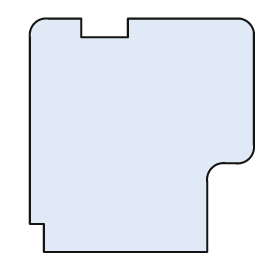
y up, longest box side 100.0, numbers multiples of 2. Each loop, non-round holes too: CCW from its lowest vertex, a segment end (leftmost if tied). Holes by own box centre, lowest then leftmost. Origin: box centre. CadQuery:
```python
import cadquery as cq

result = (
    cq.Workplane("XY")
    .moveTo(-42.0, -50.0)
    .lineTo(28.0, -50.0)
    .lineTo(28.0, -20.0)
    .threePointArc((30.0, -14.0), (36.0, -12.0))
    .lineTo(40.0, -12.0)
    .threePointArc((46.0, -10.0), (48.0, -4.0))
    .lineTo(48.0, 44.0)
    .threePointArc((46.0, 48.0), (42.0, 50.0))
    .lineTo(-6.0, 50.0)
    .lineTo(-6.0, 42.0)
    .lineTo(-26.0, 42.0)
    .lineTo(-26.0, 50.0)
    .lineTo(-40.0, 50.0)
    .threePointArc((-46.0, 48.0), (-48.0, 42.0))
    .lineTo(-48.0, -38.0)
    .lineTo(-42.0, -38.0)
    .close()
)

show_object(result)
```